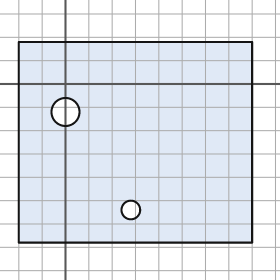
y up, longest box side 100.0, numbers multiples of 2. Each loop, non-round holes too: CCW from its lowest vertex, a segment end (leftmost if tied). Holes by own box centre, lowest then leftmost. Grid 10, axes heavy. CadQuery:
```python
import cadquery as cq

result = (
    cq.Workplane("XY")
    .moveTo(-20.0, -68.0)
    .lineTo(80.0, -68.0)
    .lineTo(80.0, 18.0)
    .lineTo(-20.0, 18.0)
    .close()
    .moveTo(28.0, -54.0)
    .circle(4.0)
    .moveTo(0.0, -12.0)
    .circle(6.0)
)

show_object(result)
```